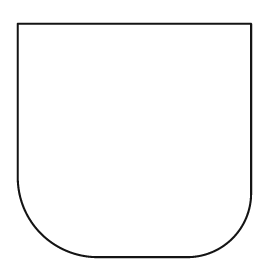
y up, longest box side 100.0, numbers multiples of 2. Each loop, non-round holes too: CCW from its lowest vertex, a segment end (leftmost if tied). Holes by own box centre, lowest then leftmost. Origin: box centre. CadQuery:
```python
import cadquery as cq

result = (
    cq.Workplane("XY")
    .moveTo(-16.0, -50.0)
    .lineTo(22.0, -50.0)
    .threePointArc((42.0, -42.0), (50.0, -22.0))
    .lineTo(50.0, 50.0)
    .lineTo(-50.0, 50.0)
    .lineTo(-50.0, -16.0)
    .threePointArc((-40.0, -40.0), (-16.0, -50.0))
    .close()
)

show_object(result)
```